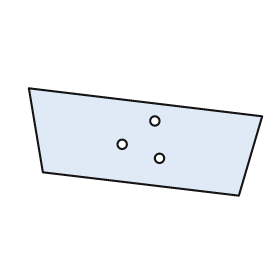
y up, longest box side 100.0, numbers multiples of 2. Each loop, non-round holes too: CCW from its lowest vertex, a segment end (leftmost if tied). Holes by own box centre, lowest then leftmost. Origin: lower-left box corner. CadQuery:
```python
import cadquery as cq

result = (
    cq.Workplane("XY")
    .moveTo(90.0, 0.0)
    .lineTo(100.0, 34.0)
    .lineTo(0.0, 46.0)
    .lineTo(6.0, 10.0)
    .close()
    .moveTo(56.0, 16.0)
    .circle(2.0)
    .moveTo(40.0, 22.0)
    .circle(2.0)
    .moveTo(54.0, 32.0)
    .circle(2.0)
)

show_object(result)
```